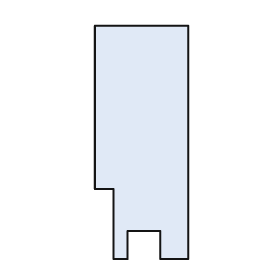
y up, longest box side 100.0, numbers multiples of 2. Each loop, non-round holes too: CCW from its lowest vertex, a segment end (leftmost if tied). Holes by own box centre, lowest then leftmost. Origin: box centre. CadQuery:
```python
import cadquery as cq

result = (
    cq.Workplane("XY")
    .moveTo(-12.0, -50.0)
    .lineTo(-6.0, -50.0)
    .lineTo(-6.0, -38.0)
    .lineTo(8.0, -38.0)
    .lineTo(8.0, -50.0)
    .lineTo(20.0, -50.0)
    .lineTo(20.0, 50.0)
    .lineTo(-20.0, 50.0)
    .lineTo(-20.0, -20.0)
    .lineTo(-12.0, -20.0)
    .close()
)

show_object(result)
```